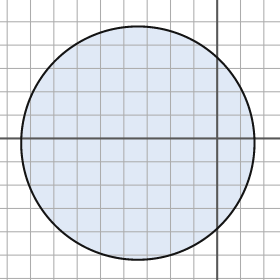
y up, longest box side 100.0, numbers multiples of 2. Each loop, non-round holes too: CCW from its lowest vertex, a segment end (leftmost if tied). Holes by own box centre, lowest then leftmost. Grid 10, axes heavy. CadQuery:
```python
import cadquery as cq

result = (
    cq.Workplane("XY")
    .moveTo(-34.0, -2.0)
    .circle(50.0)
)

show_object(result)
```